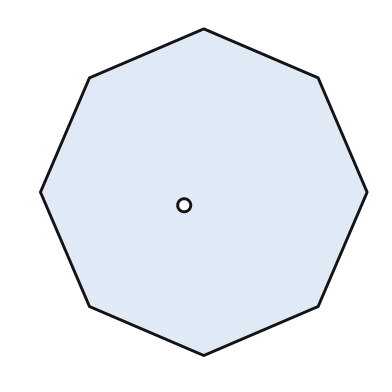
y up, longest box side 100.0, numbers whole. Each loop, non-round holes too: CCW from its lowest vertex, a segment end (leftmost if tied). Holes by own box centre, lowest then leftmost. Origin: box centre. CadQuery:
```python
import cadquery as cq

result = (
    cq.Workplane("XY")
    .moveTo(0.0, -50.0)
    .lineTo(35.0, -35.0)
    .lineTo(50.0, 0.0)
    .lineTo(35.0, 35.0)
    .lineTo(0.0, 50.0)
    .lineTo(-35.0, 35.0)
    .lineTo(-50.0, 0.0)
    .lineTo(-35.0, -35.0)
    .close()
    .moveTo(-6.0, -4.0)
    .circle(2.0)
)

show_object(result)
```